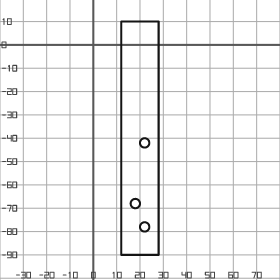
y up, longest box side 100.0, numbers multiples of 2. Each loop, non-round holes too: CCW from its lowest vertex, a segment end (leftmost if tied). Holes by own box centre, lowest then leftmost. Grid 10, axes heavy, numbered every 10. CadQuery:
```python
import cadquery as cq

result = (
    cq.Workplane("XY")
    .moveTo(12.0, -90.0)
    .lineTo(28.0, -90.0)
    .lineTo(28.0, 10.0)
    .lineTo(12.0, 10.0)
    .close()
    .moveTo(22.0, -78.0)
    .circle(2.0)
    .moveTo(18.0, -68.0)
    .circle(2.0)
    .moveTo(22.0, -42.0)
    .circle(2.0)
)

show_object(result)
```